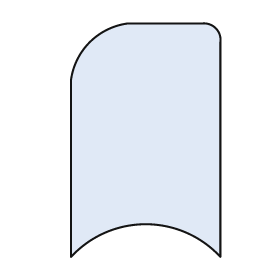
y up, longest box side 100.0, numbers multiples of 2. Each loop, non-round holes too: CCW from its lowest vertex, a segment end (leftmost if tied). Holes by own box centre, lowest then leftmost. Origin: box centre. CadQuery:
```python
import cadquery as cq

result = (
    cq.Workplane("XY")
    .moveTo(-32.0, -50.0)
    .threePointArc((0.0, -36.0), (32.0, -50.0))
    .lineTo(32.0, 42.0)
    .threePointArc((30.0, 48.0), (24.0, 50.0))
    .lineTo(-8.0, 50.0)
    .threePointArc((-24.0, 42.0), (-32.0, 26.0))
    .close()
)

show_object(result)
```